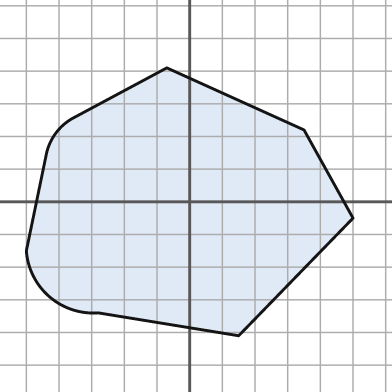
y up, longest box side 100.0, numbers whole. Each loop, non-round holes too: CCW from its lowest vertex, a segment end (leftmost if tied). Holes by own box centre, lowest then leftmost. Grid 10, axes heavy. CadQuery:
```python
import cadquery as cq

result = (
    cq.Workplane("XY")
    .moveTo(15.0, -41.0)
    .lineTo(50.0, -5.0)
    .lineTo(35.0, 22.0)
    .lineTo(-7.0, 41.0)
    .lineTo(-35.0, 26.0)
    .threePointArc((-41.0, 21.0), (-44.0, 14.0))
    .lineTo(-50.0, -15.0)
    .threePointArc((-43.0, -29.0), (-28.0, -34.0))
    .close()
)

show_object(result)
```